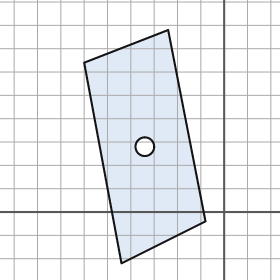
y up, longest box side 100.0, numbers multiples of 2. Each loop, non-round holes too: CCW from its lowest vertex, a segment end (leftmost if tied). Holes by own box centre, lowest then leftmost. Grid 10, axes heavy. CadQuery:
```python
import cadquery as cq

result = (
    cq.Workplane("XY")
    .moveTo(-44.0, -22.0)
    .lineTo(-8.0, -4.0)
    .lineTo(-24.0, 78.0)
    .lineTo(-60.0, 64.0)
    .close()
    .moveTo(-34.0, 28.0)
    .circle(4.0)
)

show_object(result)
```